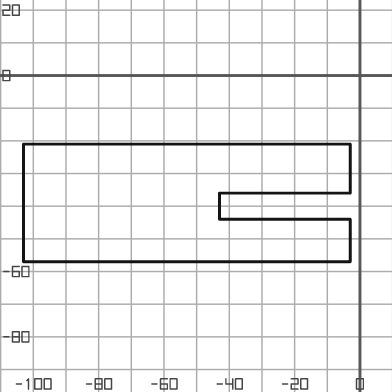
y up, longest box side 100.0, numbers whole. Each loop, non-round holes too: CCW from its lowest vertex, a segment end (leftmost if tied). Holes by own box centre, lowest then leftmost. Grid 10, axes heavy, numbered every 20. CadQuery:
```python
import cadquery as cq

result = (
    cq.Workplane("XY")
    .moveTo(-103.0, -57.0)
    .lineTo(-3.0, -57.0)
    .lineTo(-3.0, -44.0)
    .lineTo(-43.0, -44.0)
    .lineTo(-43.0, -36.0)
    .lineTo(-3.0, -36.0)
    .lineTo(-3.0, -21.0)
    .lineTo(-103.0, -21.0)
    .close()
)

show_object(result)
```